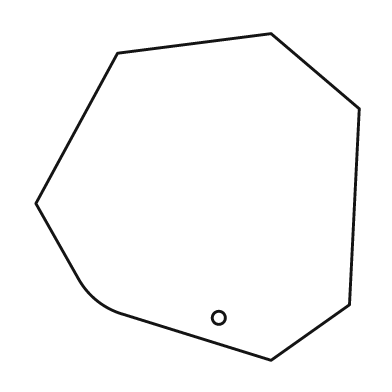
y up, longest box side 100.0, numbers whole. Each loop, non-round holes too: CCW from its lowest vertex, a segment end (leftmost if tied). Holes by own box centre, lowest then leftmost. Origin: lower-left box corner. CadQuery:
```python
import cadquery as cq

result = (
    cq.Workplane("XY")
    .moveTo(72.0, 0.0)
    .lineTo(96.0, 17.0)
    .lineTo(99.0, 77.0)
    .lineTo(72.0, 100.0)
    .lineTo(25.0, 94.0)
    .lineTo(0.0, 48.0)
    .lineTo(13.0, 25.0)
    .threePointArc((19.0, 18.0), (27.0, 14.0))
    .close()
    .moveTo(56.0, 13.0)
    .circle(2.0)
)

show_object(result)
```